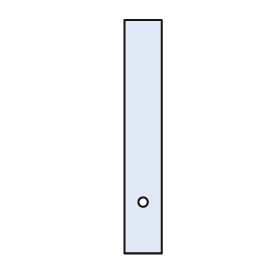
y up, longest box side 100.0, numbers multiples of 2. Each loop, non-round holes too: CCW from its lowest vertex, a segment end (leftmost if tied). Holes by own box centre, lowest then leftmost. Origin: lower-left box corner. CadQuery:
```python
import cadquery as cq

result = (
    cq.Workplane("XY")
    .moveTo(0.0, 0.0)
    .lineTo(16.0, 0.0)
    .lineTo(16.0, 100.0)
    .lineTo(0.0, 100.0)
    .close()
    .moveTo(8.0, 22.0)
    .circle(2.0)
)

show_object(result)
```